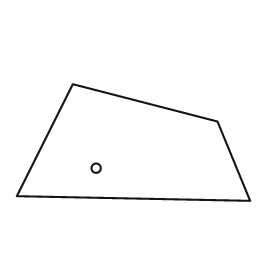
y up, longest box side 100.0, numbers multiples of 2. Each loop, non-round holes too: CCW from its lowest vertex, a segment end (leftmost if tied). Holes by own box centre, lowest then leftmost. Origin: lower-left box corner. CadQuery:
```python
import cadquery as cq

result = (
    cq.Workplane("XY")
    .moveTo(100.0, 0.0)
    .lineTo(86.0, 34.0)
    .lineTo(24.0, 50.0)
    .lineTo(0.0, 2.0)
    .close()
    .moveTo(34.0, 14.0)
    .circle(2.0)
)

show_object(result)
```